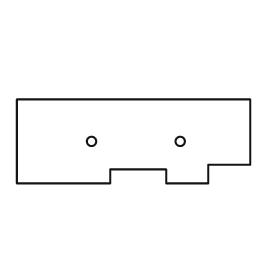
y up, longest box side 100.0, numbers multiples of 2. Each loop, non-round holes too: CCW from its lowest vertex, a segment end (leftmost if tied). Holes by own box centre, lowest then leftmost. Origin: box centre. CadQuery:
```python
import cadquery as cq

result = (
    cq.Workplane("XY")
    .moveTo(-50.0, -18.0)
    .lineTo(-10.0, -18.0)
    .lineTo(-10.0, -12.0)
    .lineTo(14.0, -12.0)
    .lineTo(14.0, -18.0)
    .lineTo(32.0, -18.0)
    .lineTo(32.0, -10.0)
    .lineTo(50.0, -10.0)
    .lineTo(50.0, 18.0)
    .lineTo(-50.0, 18.0)
    .close()
    .moveTo(-18.0, 0.0)
    .circle(2.0)
    .moveTo(20.0, 0.0)
    .circle(2.0)
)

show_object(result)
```